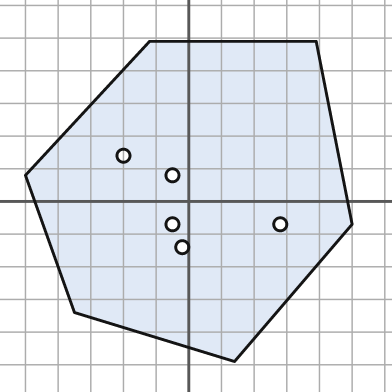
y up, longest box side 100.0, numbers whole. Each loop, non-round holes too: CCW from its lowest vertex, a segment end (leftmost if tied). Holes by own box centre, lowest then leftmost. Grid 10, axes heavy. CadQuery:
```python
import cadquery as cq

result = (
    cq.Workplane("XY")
    .moveTo(14.0, -49.0)
    .lineTo(50.0, -7.0)
    .lineTo(39.0, 49.0)
    .lineTo(-12.0, 49.0)
    .lineTo(-50.0, 8.0)
    .lineTo(-35.0, -34.0)
    .close()
    .moveTo(-2.0, -14.0)
    .circle(2.0)
    .moveTo(-5.0, -7.0)
    .circle(2.0)
    .moveTo(28.0, -7.0)
    .circle(2.0)
    .moveTo(-5.0, 8.0)
    .circle(2.0)
    .moveTo(-20.0, 14.0)
    .circle(2.0)
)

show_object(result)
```